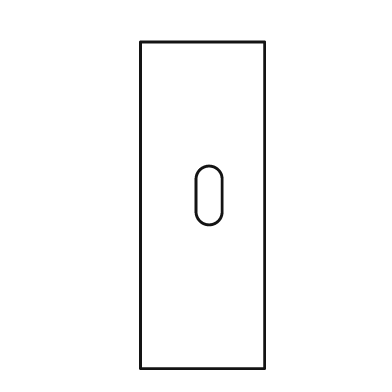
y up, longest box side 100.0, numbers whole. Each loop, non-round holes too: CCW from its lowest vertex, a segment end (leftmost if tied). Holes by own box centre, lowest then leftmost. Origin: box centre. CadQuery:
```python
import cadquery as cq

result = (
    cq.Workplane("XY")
    .moveTo(-19.0, -50.0)
    .lineTo(19.0, -50.0)
    .lineTo(19.0, 50.0)
    .lineTo(-19.0, 50.0)
    .close()
    .moveTo(-2.0, -2.0)
    .threePointArc((2.0, -6.0), (6.0, -2.0))
    .lineTo(6.0, 8.0)
    .threePointArc((2.0, 12.0), (-2.0, 8.0))
    .close()
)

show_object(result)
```